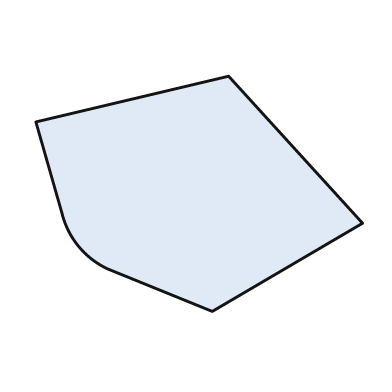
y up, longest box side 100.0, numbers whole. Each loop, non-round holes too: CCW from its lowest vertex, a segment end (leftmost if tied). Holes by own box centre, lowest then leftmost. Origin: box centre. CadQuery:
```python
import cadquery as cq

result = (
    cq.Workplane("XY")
    .moveTo(4.0, -36.0)
    .lineTo(50.0, -9.0)
    .lineTo(9.0, 36.0)
    .lineTo(-50.0, 22.0)
    .lineTo(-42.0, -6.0)
    .threePointArc((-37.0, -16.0), (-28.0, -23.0))
    .close()
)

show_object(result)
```